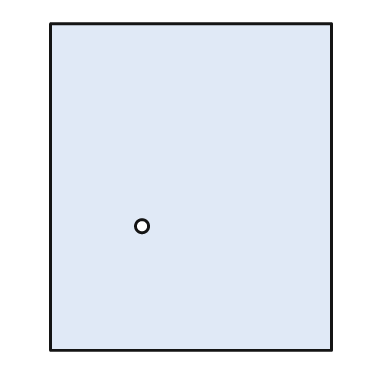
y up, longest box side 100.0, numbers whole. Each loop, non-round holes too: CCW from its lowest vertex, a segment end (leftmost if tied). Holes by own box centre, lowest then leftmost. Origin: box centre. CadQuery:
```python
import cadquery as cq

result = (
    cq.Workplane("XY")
    .moveTo(-43.0, -50.0)
    .lineTo(43.0, -50.0)
    .lineTo(43.0, 50.0)
    .lineTo(-43.0, 50.0)
    .close()
    .moveTo(-15.0, -12.0)
    .circle(2.0)
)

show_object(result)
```